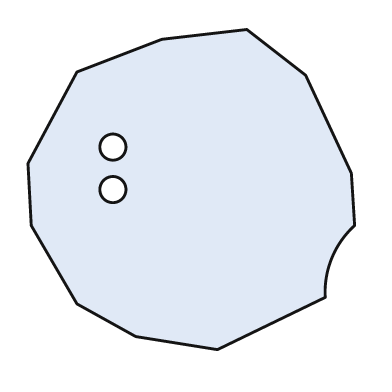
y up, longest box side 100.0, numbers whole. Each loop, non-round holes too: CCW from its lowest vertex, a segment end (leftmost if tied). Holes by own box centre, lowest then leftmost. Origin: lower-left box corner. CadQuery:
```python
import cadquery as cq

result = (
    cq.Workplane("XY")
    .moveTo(58.0, 0.0)
    .lineTo(91.0, 16.0)
    .threePointArc((93.0, 28.0), (100.0, 38.0))
    .lineTo(99.0, 54.0)
    .lineTo(85.0, 84.0)
    .lineTo(67.0, 98.0)
    .lineTo(41.0, 95.0)
    .lineTo(15.0, 85.0)
    .lineTo(0.0, 57.0)
    .lineTo(1.0, 38.0)
    .lineTo(15.0, 14.0)
    .lineTo(33.0, 4.0)
    .close()
    .moveTo(26.0, 49.0)
    .circle(4.0)
    .moveTo(26.0, 62.0)
    .circle(4.0)
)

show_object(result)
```